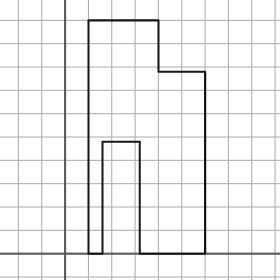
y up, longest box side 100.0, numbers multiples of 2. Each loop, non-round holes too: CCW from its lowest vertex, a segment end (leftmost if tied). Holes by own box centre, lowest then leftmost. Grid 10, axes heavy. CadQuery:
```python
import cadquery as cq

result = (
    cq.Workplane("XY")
    .moveTo(10.0, 0.0)
    .lineTo(16.0, 0.0)
    .lineTo(16.0, 48.0)
    .lineTo(32.0, 48.0)
    .lineTo(32.0, 0.0)
    .lineTo(60.0, 0.0)
    .lineTo(60.0, 78.0)
    .lineTo(40.0, 78.0)
    .lineTo(40.0, 100.0)
    .lineTo(10.0, 100.0)
    .close()
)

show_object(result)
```